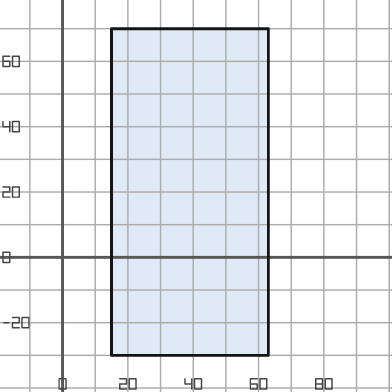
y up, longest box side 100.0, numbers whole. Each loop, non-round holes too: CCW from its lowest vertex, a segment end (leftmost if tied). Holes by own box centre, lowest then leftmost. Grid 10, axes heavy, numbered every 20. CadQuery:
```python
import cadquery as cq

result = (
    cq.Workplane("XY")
    .moveTo(15.0, -30.0)
    .lineTo(63.0, -30.0)
    .lineTo(63.0, 70.0)
    .lineTo(15.0, 70.0)
    .close()
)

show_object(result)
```